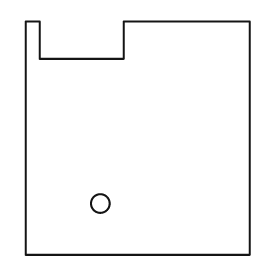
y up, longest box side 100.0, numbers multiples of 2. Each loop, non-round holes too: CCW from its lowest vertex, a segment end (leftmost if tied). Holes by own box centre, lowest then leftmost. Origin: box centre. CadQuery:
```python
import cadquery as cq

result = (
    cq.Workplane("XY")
    .moveTo(-48.0, -50.0)
    .lineTo(48.0, -50.0)
    .lineTo(48.0, 50.0)
    .lineTo(-6.0, 50.0)
    .lineTo(-6.0, 34.0)
    .lineTo(-42.0, 34.0)
    .lineTo(-42.0, 50.0)
    .lineTo(-48.0, 50.0)
    .close()
    .moveTo(-16.0, -28.0)
    .circle(4.0)
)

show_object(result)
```